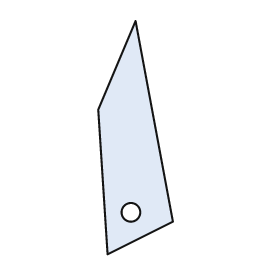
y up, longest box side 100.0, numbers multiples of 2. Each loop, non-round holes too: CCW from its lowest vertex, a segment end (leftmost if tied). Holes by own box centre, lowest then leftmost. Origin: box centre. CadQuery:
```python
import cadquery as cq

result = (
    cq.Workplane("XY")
    .moveTo(-12.0, -50.0)
    .lineTo(16.0, -36.0)
    .lineTo(0.0, 50.0)
    .lineTo(-16.0, 12.0)
    .close()
    .moveTo(-2.0, -32.0)
    .circle(4.0)
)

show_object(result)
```